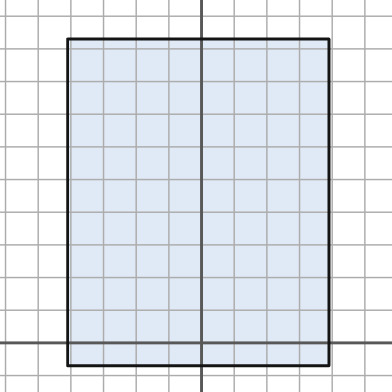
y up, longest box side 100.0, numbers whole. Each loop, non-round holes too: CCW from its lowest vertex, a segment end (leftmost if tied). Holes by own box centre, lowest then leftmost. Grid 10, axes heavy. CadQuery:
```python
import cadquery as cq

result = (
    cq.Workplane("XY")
    .moveTo(-41.0, -7.0)
    .lineTo(39.0, -7.0)
    .lineTo(39.0, 93.0)
    .lineTo(-41.0, 93.0)
    .close()
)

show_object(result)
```